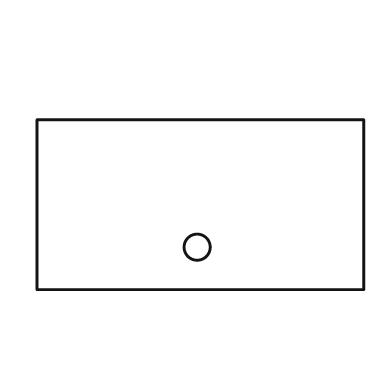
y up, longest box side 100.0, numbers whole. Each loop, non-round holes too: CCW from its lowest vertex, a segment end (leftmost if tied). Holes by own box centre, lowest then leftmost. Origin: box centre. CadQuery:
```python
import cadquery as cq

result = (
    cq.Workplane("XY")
    .moveTo(-50.0, -26.0)
    .lineTo(50.0, -26.0)
    .lineTo(50.0, 26.0)
    .lineTo(-50.0, 26.0)
    .close()
    .moveTo(-1.0, -13.0)
    .circle(4.0)
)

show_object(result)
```